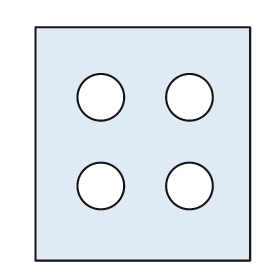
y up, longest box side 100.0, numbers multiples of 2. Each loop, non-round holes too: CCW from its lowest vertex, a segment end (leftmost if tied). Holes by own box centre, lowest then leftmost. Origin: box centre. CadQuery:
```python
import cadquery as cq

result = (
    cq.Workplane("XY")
    .moveTo(-46.0, -50.0)
    .lineTo(46.0, -50.0)
    .lineTo(46.0, 50.0)
    .lineTo(-46.0, 50.0)
    .close()
    .moveTo(-18.0, -18.0)
    .circle(10.0)
    .moveTo(20.0, -18.0)
    .circle(10.0)
    .moveTo(-18.0, 20.0)
    .circle(10.0)
    .moveTo(20.0, 20.0)
    .circle(10.0)
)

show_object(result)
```